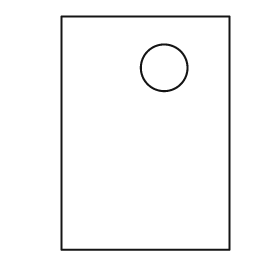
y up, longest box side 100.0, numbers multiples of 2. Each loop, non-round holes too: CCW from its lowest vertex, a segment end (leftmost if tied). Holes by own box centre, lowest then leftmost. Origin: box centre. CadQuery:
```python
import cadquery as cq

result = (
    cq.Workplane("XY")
    .moveTo(-36.0, -50.0)
    .lineTo(36.0, -50.0)
    .lineTo(36.0, 50.0)
    .lineTo(-36.0, 50.0)
    .close()
    .moveTo(8.0, 28.0)
    .circle(10.0)
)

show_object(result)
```